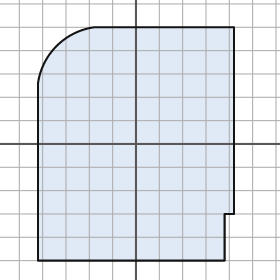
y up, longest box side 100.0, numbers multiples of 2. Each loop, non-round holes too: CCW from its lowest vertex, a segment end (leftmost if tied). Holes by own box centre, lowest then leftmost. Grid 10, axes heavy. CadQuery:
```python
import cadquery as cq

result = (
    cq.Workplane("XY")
    .moveTo(-42.0, -50.0)
    .lineTo(38.0, -50.0)
    .lineTo(38.0, -30.0)
    .lineTo(42.0, -30.0)
    .lineTo(42.0, 50.0)
    .lineTo(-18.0, 50.0)
    .threePointArc((-34.0, 42.0), (-42.0, 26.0))
    .close()
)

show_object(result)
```